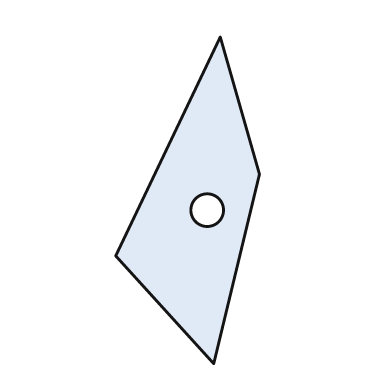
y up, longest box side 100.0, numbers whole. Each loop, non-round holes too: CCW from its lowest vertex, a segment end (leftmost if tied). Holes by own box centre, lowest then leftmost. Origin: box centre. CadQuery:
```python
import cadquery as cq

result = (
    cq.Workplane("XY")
    .moveTo(8.0, -50.0)
    .lineTo(22.0, 8.0)
    .lineTo(10.0, 50.0)
    .lineTo(-22.0, -17.0)
    .close()
    .moveTo(6.0, -3.0)
    .circle(5.0)
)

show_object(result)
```